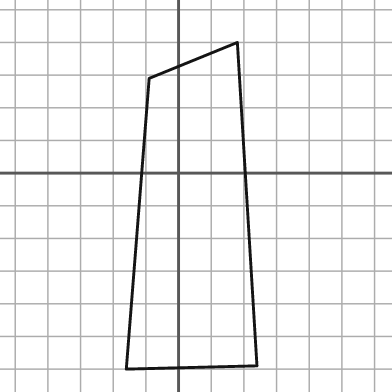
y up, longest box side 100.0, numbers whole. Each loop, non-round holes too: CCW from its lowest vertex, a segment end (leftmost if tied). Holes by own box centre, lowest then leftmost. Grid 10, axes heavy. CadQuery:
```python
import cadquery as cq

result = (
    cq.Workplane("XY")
    .moveTo(-16.0, -60.0)
    .lineTo(24.0, -59.0)
    .lineTo(18.0, 40.0)
    .lineTo(-9.0, 29.0)
    .close()
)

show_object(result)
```